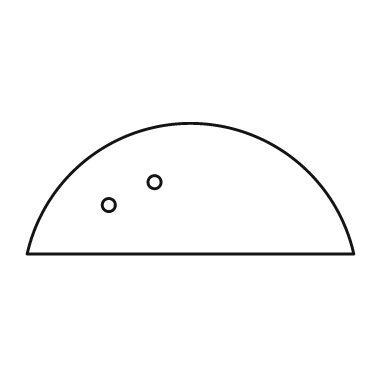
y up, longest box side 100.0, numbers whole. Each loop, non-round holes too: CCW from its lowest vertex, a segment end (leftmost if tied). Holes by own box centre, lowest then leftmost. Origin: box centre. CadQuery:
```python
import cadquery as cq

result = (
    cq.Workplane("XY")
    .moveTo(-50.0, -20.0)
    .lineTo(50.0, -20.0)
    .threePointArc((0.0, 20.0), (-50.0, -20.0))
    .close()
    .moveTo(-25.0, -5.0)
    .circle(2.0)
    .moveTo(-11.0, 2.0)
    .circle(2.0)
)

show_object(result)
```